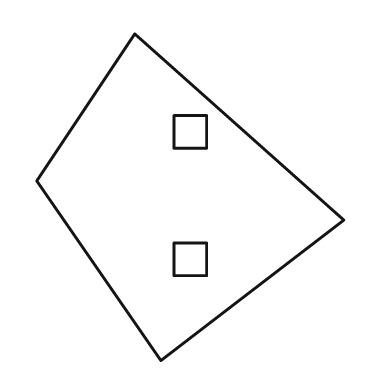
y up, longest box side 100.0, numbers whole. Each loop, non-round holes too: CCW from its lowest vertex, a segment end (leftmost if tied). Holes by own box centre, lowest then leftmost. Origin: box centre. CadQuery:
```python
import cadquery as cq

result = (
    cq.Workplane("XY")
    .moveTo(-9.0, -50.0)
    .lineTo(47.0, -7.0)
    .lineTo(-17.0, 50.0)
    .lineTo(-47.0, 5.0)
    .close()
    .moveTo(-5.0, -24.0)
    .lineTo(5.0, -24.0)
    .lineTo(5.0, -14.0)
    .lineTo(-5.0, -14.0)
    .close()
    .moveTo(-5.0, 15.0)
    .lineTo(5.0, 15.0)
    .lineTo(5.0, 25.0)
    .lineTo(-5.0, 25.0)
    .close()
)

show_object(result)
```